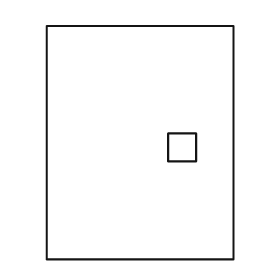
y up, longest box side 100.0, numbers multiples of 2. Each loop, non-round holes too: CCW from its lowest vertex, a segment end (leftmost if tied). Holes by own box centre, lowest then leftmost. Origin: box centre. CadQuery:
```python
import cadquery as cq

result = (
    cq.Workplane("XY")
    .moveTo(-40.0, -50.0)
    .lineTo(40.0, -50.0)
    .lineTo(40.0, 50.0)
    .lineTo(-40.0, 50.0)
    .close()
    .moveTo(12.0, -8.0)
    .lineTo(24.0, -8.0)
    .lineTo(24.0, 4.0)
    .lineTo(12.0, 4.0)
    .close()
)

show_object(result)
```